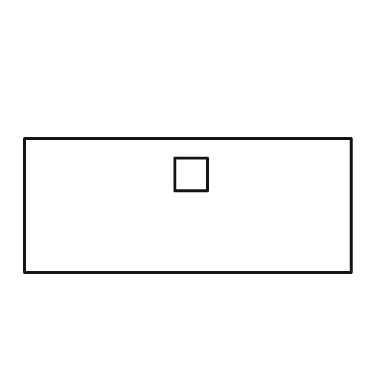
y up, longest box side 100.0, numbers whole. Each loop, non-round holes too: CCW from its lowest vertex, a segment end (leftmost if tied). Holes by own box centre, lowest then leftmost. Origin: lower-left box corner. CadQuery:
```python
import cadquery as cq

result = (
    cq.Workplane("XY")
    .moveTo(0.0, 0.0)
    .lineTo(100.0, 0.0)
    .lineTo(100.0, 41.0)
    .lineTo(0.0, 41.0)
    .close()
    .moveTo(46.0, 25.0)
    .lineTo(56.0, 25.0)
    .lineTo(56.0, 35.0)
    .lineTo(46.0, 35.0)
    .close()
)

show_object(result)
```